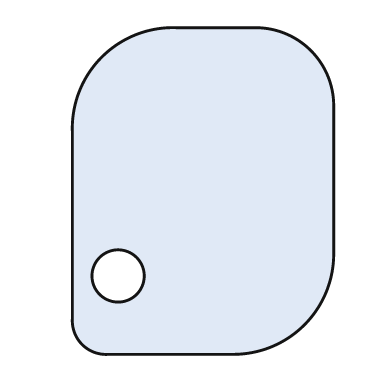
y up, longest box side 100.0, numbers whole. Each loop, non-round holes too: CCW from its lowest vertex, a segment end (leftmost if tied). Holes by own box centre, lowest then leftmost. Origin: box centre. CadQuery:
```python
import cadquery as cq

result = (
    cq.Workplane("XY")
    .moveTo(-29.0, -50.0)
    .lineTo(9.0, -50.0)
    .threePointArc((31.0, -41.0), (40.0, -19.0))
    .lineTo(40.0, 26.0)
    .threePointArc((33.0, 43.0), (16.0, 50.0))
    .lineTo(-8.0, 50.0)
    .threePointArc((-31.0, 41.0), (-40.0, 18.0))
    .lineTo(-40.0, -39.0)
    .threePointArc((-37.0, -47.0), (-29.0, -50.0))
    .close()
    .moveTo(-26.0, -26.0)
    .circle(8.0)
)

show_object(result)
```